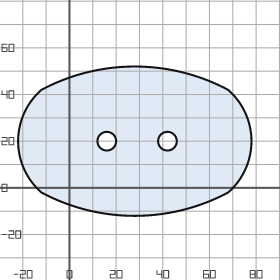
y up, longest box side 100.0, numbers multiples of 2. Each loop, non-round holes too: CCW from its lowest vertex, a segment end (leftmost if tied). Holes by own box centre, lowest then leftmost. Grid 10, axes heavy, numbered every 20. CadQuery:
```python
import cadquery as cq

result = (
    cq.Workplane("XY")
    .moveTo(-12.0, -2.0)
    .threePointArc((28.0, -12.0), (68.0, -2.0))
    .threePointArc((78.0, 20.0), (68.0, 42.0))
    .threePointArc((28.0, 52.0), (-12.0, 42.0))
    .threePointArc((-22.0, 20.0), (-12.0, -2.0))
    .close()
    .moveTo(16.0, 20.0)
    .circle(4.0)
    .moveTo(42.0, 20.0)
    .circle(4.0)
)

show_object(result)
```